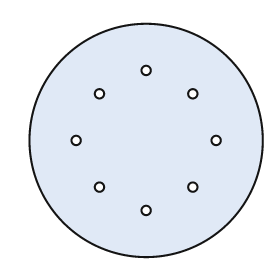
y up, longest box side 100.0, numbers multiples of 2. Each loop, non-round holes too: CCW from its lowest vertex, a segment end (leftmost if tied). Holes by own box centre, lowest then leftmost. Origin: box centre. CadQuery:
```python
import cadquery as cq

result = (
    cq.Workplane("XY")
    .moveTo(0.0, 0.0)
    .circle(50.0)
    .moveTo(0.0, -30.0)
    .circle(2.0)
    .moveTo(-20.0, -20.0)
    .circle(2.0)
    .moveTo(20.0, -20.0)
    .circle(2.0)
    .moveTo(-30.0, 0.0)
    .circle(2.0)
    .moveTo(30.0, 0.0)
    .circle(2.0)
    .moveTo(-20.0, 20.0)
    .circle(2.0)
    .moveTo(20.0, 20.0)
    .circle(2.0)
    .moveTo(0.0, 30.0)
    .circle(2.0)
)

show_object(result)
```